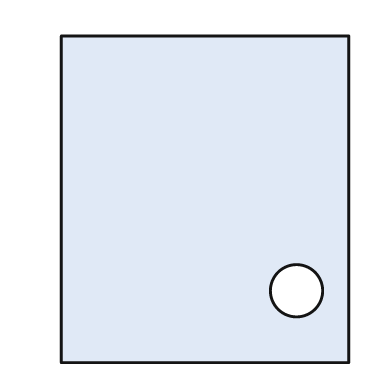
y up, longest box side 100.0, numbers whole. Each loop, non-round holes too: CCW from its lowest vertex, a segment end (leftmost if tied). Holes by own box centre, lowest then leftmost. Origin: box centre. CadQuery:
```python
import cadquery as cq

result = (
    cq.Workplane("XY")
    .moveTo(-44.0, -50.0)
    .lineTo(44.0, -50.0)
    .lineTo(44.0, 50.0)
    .lineTo(-44.0, 50.0)
    .close()
    .moveTo(28.0, -28.0)
    .circle(8.0)
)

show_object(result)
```